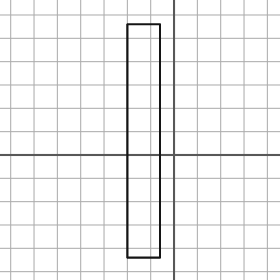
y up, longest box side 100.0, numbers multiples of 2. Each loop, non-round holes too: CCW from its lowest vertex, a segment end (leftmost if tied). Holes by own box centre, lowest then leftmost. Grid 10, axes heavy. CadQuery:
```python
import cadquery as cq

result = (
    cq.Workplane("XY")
    .moveTo(-20.0, -44.0)
    .lineTo(-6.0, -44.0)
    .lineTo(-6.0, 56.0)
    .lineTo(-20.0, 56.0)
    .close()
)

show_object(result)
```